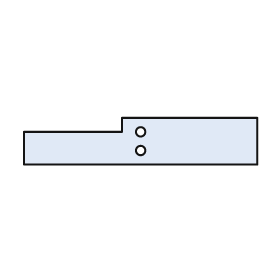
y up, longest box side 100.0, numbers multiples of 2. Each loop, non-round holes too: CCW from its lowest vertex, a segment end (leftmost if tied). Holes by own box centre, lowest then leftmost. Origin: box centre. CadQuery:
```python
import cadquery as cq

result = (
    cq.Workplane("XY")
    .moveTo(-50.0, -10.0)
    .lineTo(50.0, -10.0)
    .lineTo(50.0, 10.0)
    .lineTo(-8.0, 10.0)
    .lineTo(-8.0, 4.0)
    .lineTo(-50.0, 4.0)
    .close()
    .moveTo(0.0, -4.0)
    .circle(2.0)
    .moveTo(0.0, 4.0)
    .circle(2.0)
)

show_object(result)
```